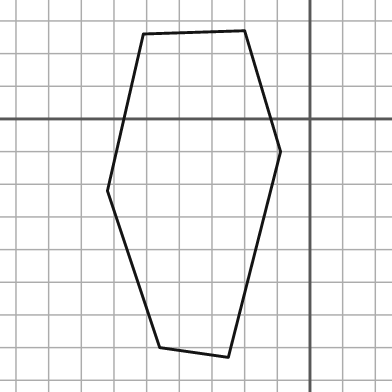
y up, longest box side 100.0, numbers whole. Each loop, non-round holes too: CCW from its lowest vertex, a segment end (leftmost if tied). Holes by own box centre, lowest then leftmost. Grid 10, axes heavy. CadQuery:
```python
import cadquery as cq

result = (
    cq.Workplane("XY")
    .moveTo(-25.0, -73.0)
    .lineTo(-9.0, -10.0)
    .lineTo(-20.0, 27.0)
    .lineTo(-51.0, 26.0)
    .lineTo(-62.0, -22.0)
    .lineTo(-46.0, -70.0)
    .close()
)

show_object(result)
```